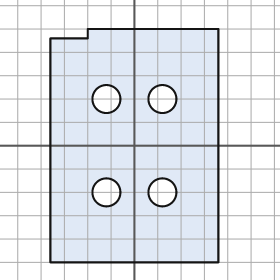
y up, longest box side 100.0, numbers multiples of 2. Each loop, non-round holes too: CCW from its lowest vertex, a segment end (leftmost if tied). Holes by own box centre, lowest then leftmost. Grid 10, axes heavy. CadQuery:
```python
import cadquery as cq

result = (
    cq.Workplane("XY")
    .moveTo(-36.0, -50.0)
    .lineTo(36.0, -50.0)
    .lineTo(36.0, 50.0)
    .lineTo(-20.0, 50.0)
    .lineTo(-20.0, 46.0)
    .lineTo(-36.0, 46.0)
    .close()
    .moveTo(-12.0, -20.0)
    .circle(6.0)
    .moveTo(12.0, -20.0)
    .circle(6.0)
    .moveTo(-12.0, 20.0)
    .circle(6.0)
    .moveTo(12.0, 20.0)
    .circle(6.0)
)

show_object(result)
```